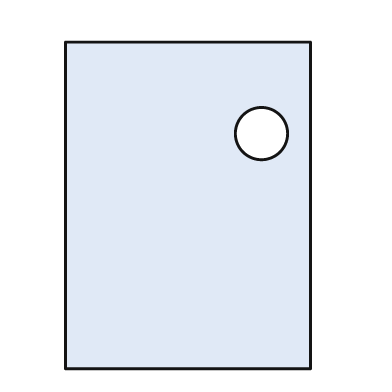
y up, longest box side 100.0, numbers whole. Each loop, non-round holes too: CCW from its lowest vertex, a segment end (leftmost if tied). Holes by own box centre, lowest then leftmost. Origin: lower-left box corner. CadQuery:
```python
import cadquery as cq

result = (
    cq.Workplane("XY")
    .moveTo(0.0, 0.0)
    .lineTo(75.0, 0.0)
    .lineTo(75.0, 100.0)
    .lineTo(0.0, 100.0)
    .close()
    .moveTo(60.0, 72.0)
    .circle(8.0)
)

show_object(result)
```